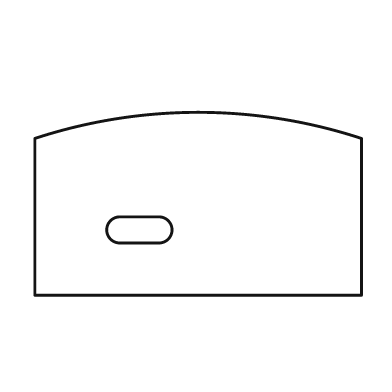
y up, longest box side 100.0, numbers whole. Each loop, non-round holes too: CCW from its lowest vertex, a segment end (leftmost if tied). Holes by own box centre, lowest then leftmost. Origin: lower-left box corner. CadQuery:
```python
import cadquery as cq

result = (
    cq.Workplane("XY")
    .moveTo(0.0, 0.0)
    .lineTo(100.0, 0.0)
    .lineTo(100.0, 48.0)
    .threePointArc((50.0, 56.0), (0.0, 48.0))
    .close()
    .moveTo(26.0, 16.0)
    .lineTo(38.0, 16.0)
    .threePointArc((42.0, 20.0), (38.0, 24.0))
    .lineTo(26.0, 24.0)
    .threePointArc((22.0, 20.0), (26.0, 16.0))
    .close()
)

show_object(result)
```